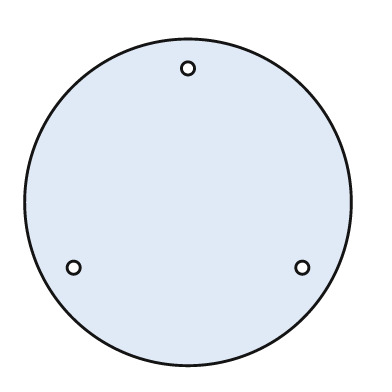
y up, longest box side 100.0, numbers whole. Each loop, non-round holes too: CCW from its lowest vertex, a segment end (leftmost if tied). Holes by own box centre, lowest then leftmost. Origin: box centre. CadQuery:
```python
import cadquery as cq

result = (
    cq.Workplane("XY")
    .moveTo(0.0, 0.0)
    .circle(50.0)
    .moveTo(-35.0, -20.0)
    .circle(2.0)
    .moveTo(35.0, -20.0)
    .circle(2.0)
    .moveTo(0.0, 41.0)
    .circle(2.0)
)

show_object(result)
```